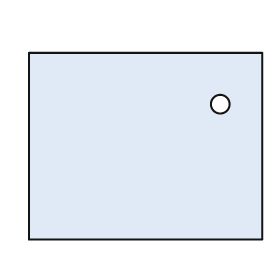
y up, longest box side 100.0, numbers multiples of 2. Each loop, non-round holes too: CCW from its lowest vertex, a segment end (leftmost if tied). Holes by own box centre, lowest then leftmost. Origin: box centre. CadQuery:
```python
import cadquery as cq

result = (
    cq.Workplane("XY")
    .moveTo(-50.0, -40.0)
    .lineTo(50.0, -40.0)
    .lineTo(50.0, 40.0)
    .lineTo(-50.0, 40.0)
    .close()
    .moveTo(32.0, 18.0)
    .circle(4.0)
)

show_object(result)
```